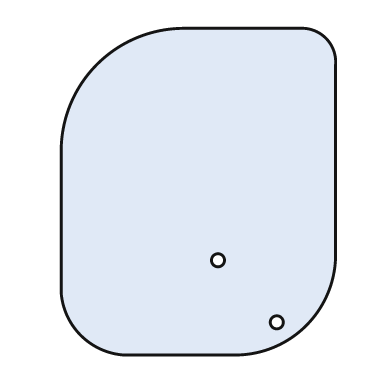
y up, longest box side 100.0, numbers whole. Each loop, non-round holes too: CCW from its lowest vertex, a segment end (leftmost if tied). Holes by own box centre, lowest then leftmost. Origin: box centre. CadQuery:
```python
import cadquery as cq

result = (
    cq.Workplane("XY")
    .moveTo(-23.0, -50.0)
    .lineTo(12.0, -50.0)
    .threePointArc((33.0, -41.0), (42.0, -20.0))
    .lineTo(42.0, 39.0)
    .threePointArc((39.0, 47.0), (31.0, 50.0))
    .lineTo(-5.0, 50.0)
    .threePointArc((-31.0, 39.0), (-42.0, 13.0))
    .lineTo(-42.0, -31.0)
    .threePointArc((-36.0, -44.0), (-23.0, -50.0))
    .close()
    .moveTo(24.0, -40.0)
    .circle(2.0)
    .moveTo(6.0, -21.0)
    .circle(2.0)
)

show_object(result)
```